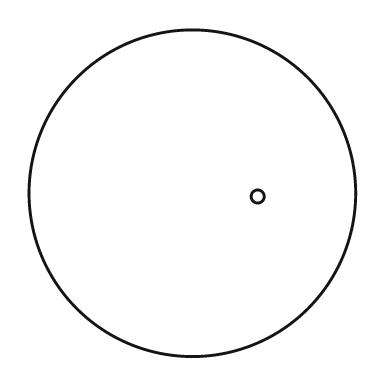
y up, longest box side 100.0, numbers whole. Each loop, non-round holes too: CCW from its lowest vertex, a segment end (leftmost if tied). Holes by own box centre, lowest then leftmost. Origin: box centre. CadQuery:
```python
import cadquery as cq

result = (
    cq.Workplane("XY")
    .moveTo(0.0, 0.0)
    .circle(50.0)
    .moveTo(20.0, -1.0)
    .circle(2.0)
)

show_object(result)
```